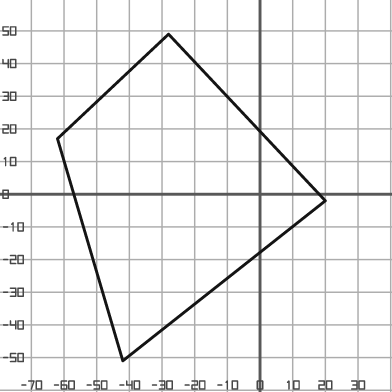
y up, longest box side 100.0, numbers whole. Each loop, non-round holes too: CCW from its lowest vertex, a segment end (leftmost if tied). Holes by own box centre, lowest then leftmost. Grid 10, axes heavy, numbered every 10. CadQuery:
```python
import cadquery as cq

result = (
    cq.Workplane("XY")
    .moveTo(-42.0, -51.0)
    .lineTo(20.0, -2.0)
    .lineTo(-28.0, 49.0)
    .lineTo(-62.0, 17.0)
    .close()
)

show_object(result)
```